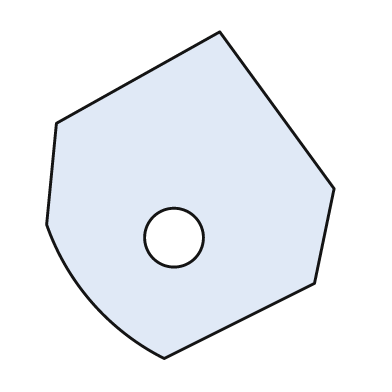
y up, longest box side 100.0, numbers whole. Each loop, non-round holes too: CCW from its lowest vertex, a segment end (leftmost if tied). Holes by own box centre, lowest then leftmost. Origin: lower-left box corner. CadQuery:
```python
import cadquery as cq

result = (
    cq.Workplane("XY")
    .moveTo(36.0, 0.0)
    .lineTo(82.0, 23.0)
    .lineTo(88.0, 52.0)
    .lineTo(53.0, 100.0)
    .lineTo(3.0, 72.0)
    .lineTo(0.0, 41.0)
    .threePointArc((14.0, 17.0), (36.0, 0.0))
    .close()
    .moveTo(39.0, 37.0)
    .circle(9.0)
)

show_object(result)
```